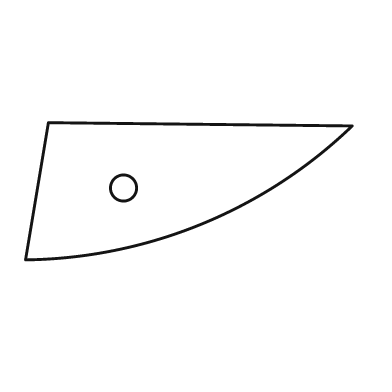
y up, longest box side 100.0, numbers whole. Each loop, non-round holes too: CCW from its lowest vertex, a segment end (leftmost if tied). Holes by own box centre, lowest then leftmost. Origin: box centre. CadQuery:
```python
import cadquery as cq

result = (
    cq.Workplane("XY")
    .moveTo(-50.0, -21.0)
    .threePointArc((4.0, -10.0), (50.0, 20.0))
    .lineTo(-43.0, 21.0)
    .close()
    .moveTo(-20.0, 1.0)
    .circle(4.0)
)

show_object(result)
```